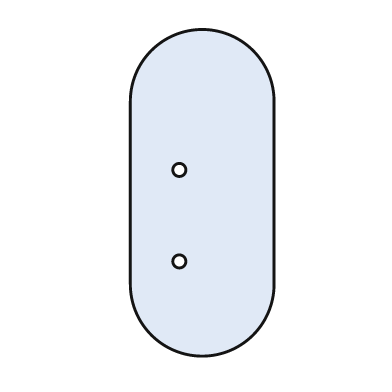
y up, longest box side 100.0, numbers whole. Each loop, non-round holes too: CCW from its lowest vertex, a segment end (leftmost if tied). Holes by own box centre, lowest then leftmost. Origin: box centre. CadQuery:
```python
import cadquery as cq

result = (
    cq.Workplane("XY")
    .moveTo(-22.0, -28.0)
    .threePointArc((0.0, -50.0), (22.0, -28.0))
    .lineTo(22.0, 28.0)
    .threePointArc((0.0, 50.0), (-22.0, 28.0))
    .close()
    .moveTo(-7.0, -21.0)
    .circle(2.0)
    .moveTo(-7.0, 7.0)
    .circle(2.0)
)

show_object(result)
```